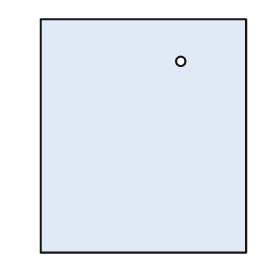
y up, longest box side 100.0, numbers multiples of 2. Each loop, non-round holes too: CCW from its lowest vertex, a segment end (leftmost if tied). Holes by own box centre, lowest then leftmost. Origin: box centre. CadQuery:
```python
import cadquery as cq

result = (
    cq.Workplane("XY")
    .moveTo(-44.0, -50.0)
    .lineTo(44.0, -50.0)
    .lineTo(44.0, 50.0)
    .lineTo(-44.0, 50.0)
    .close()
    .moveTo(16.0, 32.0)
    .circle(2.0)
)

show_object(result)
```